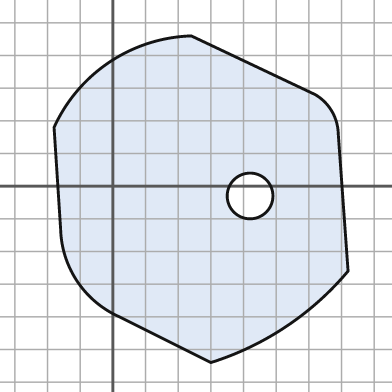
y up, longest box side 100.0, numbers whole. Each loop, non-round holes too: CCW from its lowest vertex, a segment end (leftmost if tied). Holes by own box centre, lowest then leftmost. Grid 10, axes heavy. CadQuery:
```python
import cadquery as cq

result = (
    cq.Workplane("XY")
    .moveTo(30.0, -54.0)
    .threePointArc((53.0, -43.0), (72.0, -26.0))
    .lineTo(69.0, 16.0)
    .threePointArc((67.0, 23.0), (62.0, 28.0))
    .lineTo(24.0, 46.0)
    .threePointArc((-1.0, 38.0), (-18.0, 18.0))
    .lineTo(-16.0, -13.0)
    .threePointArc((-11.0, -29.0), (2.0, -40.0))
    .close()
    .moveTo(42.0, -3.0)
    .circle(7.0)
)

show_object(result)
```